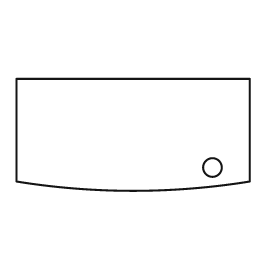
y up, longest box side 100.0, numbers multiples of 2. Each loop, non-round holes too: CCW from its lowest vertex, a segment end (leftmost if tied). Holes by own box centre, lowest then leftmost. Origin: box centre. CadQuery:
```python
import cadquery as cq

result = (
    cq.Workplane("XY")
    .moveTo(-50.0, -20.0)
    .threePointArc((0.0, -24.0), (50.0, -20.0))
    .lineTo(50.0, 24.0)
    .lineTo(-50.0, 24.0)
    .close()
    .moveTo(34.0, -14.0)
    .circle(4.0)
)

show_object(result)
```